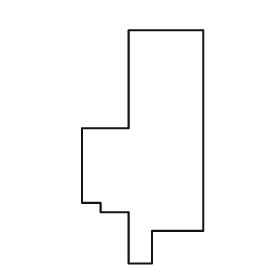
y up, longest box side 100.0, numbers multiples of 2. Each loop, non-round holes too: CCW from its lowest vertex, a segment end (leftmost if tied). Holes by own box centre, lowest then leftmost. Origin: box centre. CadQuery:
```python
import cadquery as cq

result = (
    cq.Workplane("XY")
    .moveTo(-6.0, -50.0)
    .lineTo(4.0, -50.0)
    .lineTo(4.0, -36.0)
    .lineTo(26.0, -36.0)
    .lineTo(26.0, 50.0)
    .lineTo(-6.0, 50.0)
    .lineTo(-6.0, 8.0)
    .lineTo(-26.0, 8.0)
    .lineTo(-26.0, -24.0)
    .lineTo(-18.0, -24.0)
    .lineTo(-18.0, -28.0)
    .lineTo(-6.0, -28.0)
    .close()
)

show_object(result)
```